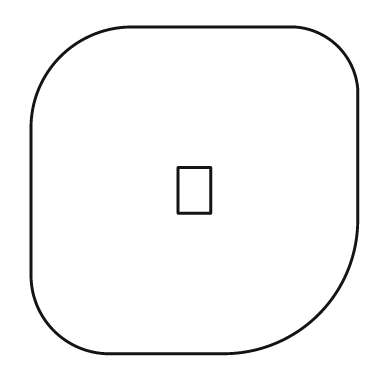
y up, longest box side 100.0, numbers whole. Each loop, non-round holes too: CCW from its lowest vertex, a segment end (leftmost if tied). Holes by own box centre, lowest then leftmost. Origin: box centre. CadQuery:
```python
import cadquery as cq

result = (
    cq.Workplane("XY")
    .moveTo(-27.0, -50.0)
    .lineTo(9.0, -50.0)
    .threePointArc((38.0, -38.0), (50.0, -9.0))
    .lineTo(50.0, 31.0)
    .threePointArc((44.0, 44.0), (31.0, 50.0))
    .lineTo(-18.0, 50.0)
    .threePointArc((-41.0, 41.0), (-50.0, 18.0))
    .lineTo(-50.0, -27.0)
    .threePointArc((-43.0, -43.0), (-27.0, -50.0))
    .close()
    .moveTo(-5.0, -7.0)
    .lineTo(5.0, -7.0)
    .lineTo(5.0, 7.0)
    .lineTo(-5.0, 7.0)
    .close()
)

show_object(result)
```